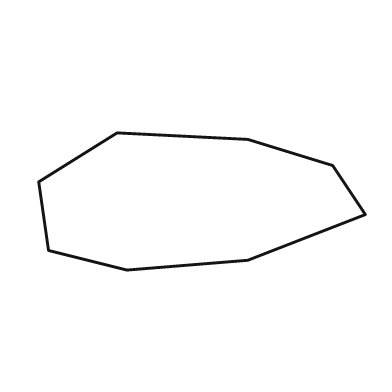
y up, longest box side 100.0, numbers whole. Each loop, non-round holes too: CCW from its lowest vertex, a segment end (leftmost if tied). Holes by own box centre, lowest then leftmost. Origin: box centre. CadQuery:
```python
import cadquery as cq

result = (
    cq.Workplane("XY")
    .moveTo(-23.0, -21.0)
    .lineTo(14.0, -18.0)
    .lineTo(50.0, -4.0)
    .lineTo(40.0, 11.0)
    .lineTo(14.0, 19.0)
    .lineTo(-26.0, 21.0)
    .lineTo(-50.0, 6.0)
    .lineTo(-47.0, -15.0)
    .close()
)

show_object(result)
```